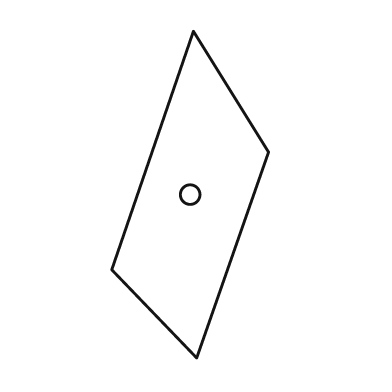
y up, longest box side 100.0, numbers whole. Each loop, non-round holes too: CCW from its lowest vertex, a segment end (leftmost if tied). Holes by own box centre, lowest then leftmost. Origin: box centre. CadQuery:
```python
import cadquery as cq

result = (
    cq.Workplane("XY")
    .moveTo(2.0, -50.0)
    .lineTo(24.0, 13.0)
    .lineTo(1.0, 50.0)
    .lineTo(-24.0, -23.0)
    .close()
    .moveTo(0.0, 0.0)
    .circle(3.0)
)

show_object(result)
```